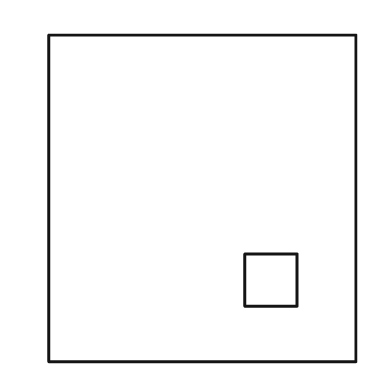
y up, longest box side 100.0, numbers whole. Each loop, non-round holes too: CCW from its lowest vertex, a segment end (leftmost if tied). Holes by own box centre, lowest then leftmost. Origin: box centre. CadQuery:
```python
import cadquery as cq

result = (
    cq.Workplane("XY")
    .moveTo(-47.0, -50.0)
    .lineTo(47.0, -50.0)
    .lineTo(47.0, 50.0)
    .lineTo(-47.0, 50.0)
    .close()
    .moveTo(13.0, -33.0)
    .lineTo(29.0, -33.0)
    .lineTo(29.0, -17.0)
    .lineTo(13.0, -17.0)
    .close()
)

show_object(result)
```